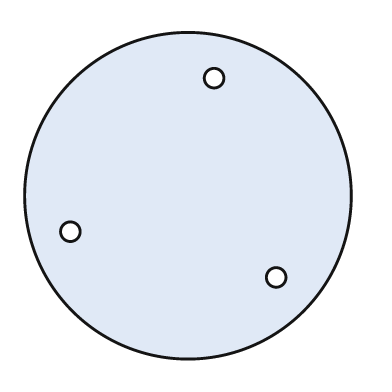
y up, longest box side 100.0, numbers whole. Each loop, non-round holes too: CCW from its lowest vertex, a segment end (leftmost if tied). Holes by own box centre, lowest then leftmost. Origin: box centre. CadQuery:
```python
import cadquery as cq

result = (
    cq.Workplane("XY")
    .moveTo(0.0, 0.0)
    .circle(50.0)
    .moveTo(27.0, -25.0)
    .circle(3.0)
    .moveTo(-36.0, -11.0)
    .circle(3.0)
    .moveTo(8.0, 36.0)
    .circle(3.0)
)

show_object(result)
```